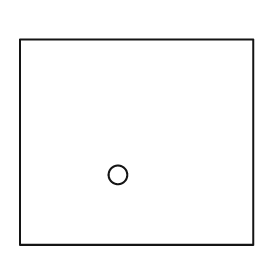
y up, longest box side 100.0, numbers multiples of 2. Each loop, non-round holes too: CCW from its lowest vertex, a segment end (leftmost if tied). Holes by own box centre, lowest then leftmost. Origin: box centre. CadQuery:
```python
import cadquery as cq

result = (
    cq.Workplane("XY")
    .moveTo(-50.0, -44.0)
    .lineTo(50.0, -44.0)
    .lineTo(50.0, 44.0)
    .lineTo(-50.0, 44.0)
    .close()
    .moveTo(-8.0, -14.0)
    .circle(4.0)
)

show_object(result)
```